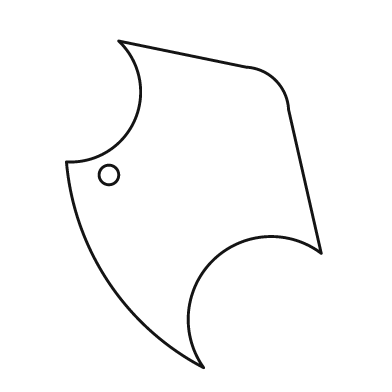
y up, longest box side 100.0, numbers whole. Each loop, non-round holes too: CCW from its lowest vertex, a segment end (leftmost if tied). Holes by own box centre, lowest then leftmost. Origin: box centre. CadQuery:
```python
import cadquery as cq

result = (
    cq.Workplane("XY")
    .moveTo(3.0, -50.0)
    .threePointArc((6.0, -17.0), (39.0, -15.0))
    .lineTo(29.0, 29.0)
    .threePointArc((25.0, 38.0), (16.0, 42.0))
    .lineTo(-23.0, 50.0)
    .threePointArc((-18.0, 26.0), (-39.0, 13.0))
    .threePointArc((-26.0, -24.0), (3.0, -50.0))
    .close()
    .moveTo(-26.0, 9.0)
    .circle(3.0)
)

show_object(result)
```